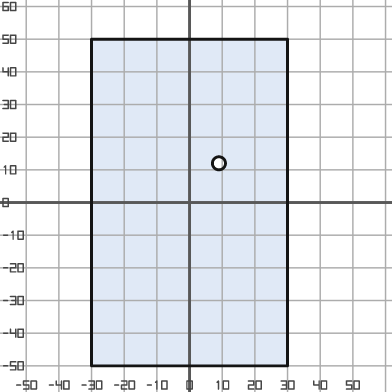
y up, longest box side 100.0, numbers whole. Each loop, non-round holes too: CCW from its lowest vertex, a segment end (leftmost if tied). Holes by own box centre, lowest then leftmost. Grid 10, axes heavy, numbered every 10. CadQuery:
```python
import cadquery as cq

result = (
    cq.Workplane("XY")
    .moveTo(-30.0, -50.0)
    .lineTo(30.0, -50.0)
    .lineTo(30.0, 50.0)
    .lineTo(-30.0, 50.0)
    .close()
    .moveTo(9.0, 12.0)
    .circle(2.0)
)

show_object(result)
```